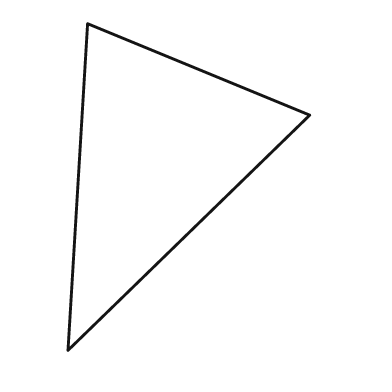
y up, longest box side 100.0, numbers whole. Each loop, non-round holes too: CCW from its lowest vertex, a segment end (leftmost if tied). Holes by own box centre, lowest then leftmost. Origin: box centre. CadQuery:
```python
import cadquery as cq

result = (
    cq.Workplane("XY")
    .moveTo(-37.0, -50.0)
    .lineTo(37.0, 22.0)
    .lineTo(-31.0, 50.0)
    .close()
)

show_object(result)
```